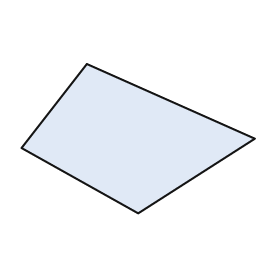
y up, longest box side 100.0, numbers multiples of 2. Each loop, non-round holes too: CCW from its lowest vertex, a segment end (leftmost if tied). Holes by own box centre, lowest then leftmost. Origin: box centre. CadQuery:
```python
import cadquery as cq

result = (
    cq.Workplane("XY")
    .moveTo(0.0, -32.0)
    .lineTo(50.0, 0.0)
    .lineTo(-22.0, 32.0)
    .lineTo(-50.0, -4.0)
    .close()
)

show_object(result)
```